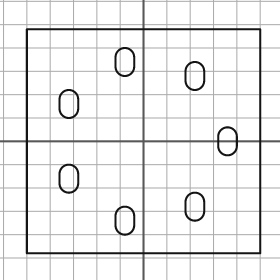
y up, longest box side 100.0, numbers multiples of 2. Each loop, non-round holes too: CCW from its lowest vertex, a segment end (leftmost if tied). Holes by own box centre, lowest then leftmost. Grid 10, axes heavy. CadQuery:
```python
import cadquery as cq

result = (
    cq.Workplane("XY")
    .moveTo(-50.0, -48.0)
    .lineTo(50.0, -48.0)
    .lineTo(50.0, 48.0)
    .lineTo(-50.0, 48.0)
    .close()
    .moveTo(-12.0, -36.0)
    .threePointArc((-8.0, -40.0), (-4.0, -36.0))
    .lineTo(-4.0, -32.0)
    .threePointArc((-8.0, -28.0), (-12.0, -32.0))
    .close()
    .moveTo(18.0, -30.0)
    .threePointArc((22.0, -34.0), (26.0, -30.0))
    .lineTo(26.0, -26.0)
    .threePointArc((22.0, -22.0), (18.0, -26.0))
    .close()
    .moveTo(-36.0, -18.0)
    .threePointArc((-32.0, -22.0), (-28.0, -18.0))
    .lineTo(-28.0, -14.0)
    .threePointArc((-32.0, -10.0), (-36.0, -14.0))
    .close()
    .moveTo(32.0, -2.0)
    .threePointArc((36.0, -6.0), (40.0, -2.0))
    .lineTo(40.0, 2.0)
    .threePointArc((36.0, 6.0), (32.0, 2.0))
    .close()
    .moveTo(-36.0, 14.0)
    .threePointArc((-32.0, 10.0), (-28.0, 14.0))
    .lineTo(-28.0, 18.0)
    .threePointArc((-32.0, 22.0), (-36.0, 18.0))
    .close()
    .moveTo(18.0, 26.0)
    .threePointArc((22.0, 22.0), (26.0, 26.0))
    .lineTo(26.0, 30.0)
    .threePointArc((22.0, 34.0), (18.0, 30.0))
    .close()
    .moveTo(-12.0, 32.0)
    .threePointArc((-8.0, 28.0), (-4.0, 32.0))
    .lineTo(-4.0, 36.0)
    .threePointArc((-8.0, 40.0), (-12.0, 36.0))
    .close()
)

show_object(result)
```